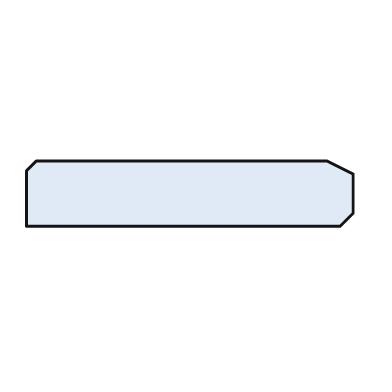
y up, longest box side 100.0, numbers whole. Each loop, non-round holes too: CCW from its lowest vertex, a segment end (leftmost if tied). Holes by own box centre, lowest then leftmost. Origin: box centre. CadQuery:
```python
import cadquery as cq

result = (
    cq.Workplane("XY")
    .moveTo(-50.0, -10.0)
    .lineTo(46.0, -10.0)
    .lineTo(50.0, -6.0)
    .lineTo(50.0, 6.0)
    .lineTo(42.0, 10.0)
    .lineTo(-47.0, 10.0)
    .lineTo(-50.0, 7.0)
    .close()
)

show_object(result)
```